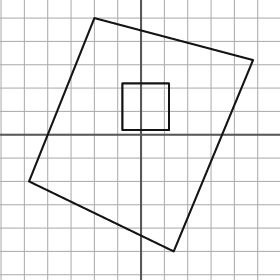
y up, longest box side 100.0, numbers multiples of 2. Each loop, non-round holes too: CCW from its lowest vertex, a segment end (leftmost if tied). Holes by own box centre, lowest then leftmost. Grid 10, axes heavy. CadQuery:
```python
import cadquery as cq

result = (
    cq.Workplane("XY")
    .moveTo(14.0, -50.0)
    .lineTo(48.0, 32.0)
    .lineTo(-20.0, 50.0)
    .lineTo(-48.0, -20.0)
    .close()
    .moveTo(-8.0, 2.0)
    .lineTo(12.0, 2.0)
    .lineTo(12.0, 22.0)
    .lineTo(-8.0, 22.0)
    .close()
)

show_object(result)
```